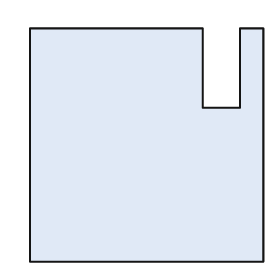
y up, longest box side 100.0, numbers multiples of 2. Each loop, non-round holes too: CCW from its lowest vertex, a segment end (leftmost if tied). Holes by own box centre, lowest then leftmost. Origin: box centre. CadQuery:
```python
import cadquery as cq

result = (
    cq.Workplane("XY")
    .moveTo(-50.0, -50.0)
    .lineTo(50.0, -50.0)
    .lineTo(50.0, 50.0)
    .lineTo(40.0, 50.0)
    .lineTo(40.0, 16.0)
    .lineTo(24.0, 16.0)
    .lineTo(24.0, 50.0)
    .lineTo(-50.0, 50.0)
    .close()
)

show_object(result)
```